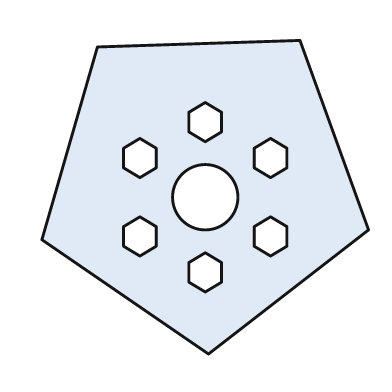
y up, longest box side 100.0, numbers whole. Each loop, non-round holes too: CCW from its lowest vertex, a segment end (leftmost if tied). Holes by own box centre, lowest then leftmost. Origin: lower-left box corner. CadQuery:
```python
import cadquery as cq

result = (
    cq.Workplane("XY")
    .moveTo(51.0, 0.0)
    .lineTo(100.0, 38.0)
    .lineTo(79.0, 96.0)
    .lineTo(17.0, 94.0)
    .lineTo(0.0, 35.0)
    .close()
    .moveTo(50.0, 19.0)
    .lineTo(55.0, 22.0)
    .lineTo(55.0, 28.0)
    .lineTo(50.0, 31.0)
    .lineTo(45.0, 28.0)
    .lineTo(45.0, 22.0)
    .close()
    .moveTo(30.0, 30.0)
    .lineTo(35.0, 33.0)
    .lineTo(35.0, 39.0)
    .lineTo(30.0, 42.0)
    .lineTo(25.0, 39.0)
    .lineTo(25.0, 33.0)
    .close()
    .moveTo(70.0, 30.0)
    .lineTo(75.0, 33.0)
    .lineTo(75.0, 39.0)
    .lineTo(70.0, 42.0)
    .lineTo(65.0, 39.0)
    .lineTo(65.0, 33.0)
    .close()
    .moveTo(50.0, 48.0)
    .circle(10.0)
    .moveTo(30.0, 54.0)
    .lineTo(35.0, 57.0)
    .lineTo(35.0, 63.0)
    .lineTo(30.0, 66.0)
    .lineTo(25.0, 63.0)
    .lineTo(25.0, 57.0)
    .close()
    .moveTo(70.0, 54.0)
    .lineTo(75.0, 57.0)
    .lineTo(75.0, 63.0)
    .lineTo(70.0, 66.0)
    .lineTo(65.0, 63.0)
    .lineTo(65.0, 57.0)
    .close()
    .moveTo(50.0, 65.0)
    .lineTo(55.0, 68.0)
    .lineTo(55.0, 74.0)
    .lineTo(50.0, 77.0)
    .lineTo(45.0, 74.0)
    .lineTo(45.0, 68.0)
    .close()
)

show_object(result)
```